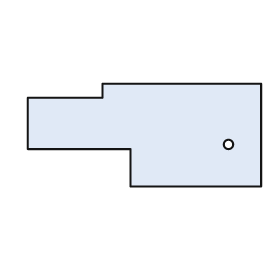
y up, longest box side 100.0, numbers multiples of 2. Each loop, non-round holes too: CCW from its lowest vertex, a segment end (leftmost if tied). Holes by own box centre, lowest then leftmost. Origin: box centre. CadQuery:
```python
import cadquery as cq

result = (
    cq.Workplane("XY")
    .moveTo(-6.0, -22.0)
    .lineTo(50.0, -22.0)
    .lineTo(50.0, 22.0)
    .lineTo(-18.0, 22.0)
    .lineTo(-18.0, 16.0)
    .lineTo(-50.0, 16.0)
    .lineTo(-50.0, -6.0)
    .lineTo(-6.0, -6.0)
    .close()
    .moveTo(36.0, -4.0)
    .circle(2.0)
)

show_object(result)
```